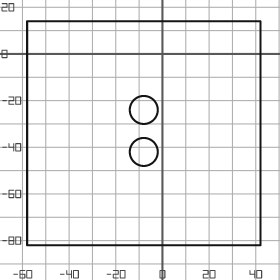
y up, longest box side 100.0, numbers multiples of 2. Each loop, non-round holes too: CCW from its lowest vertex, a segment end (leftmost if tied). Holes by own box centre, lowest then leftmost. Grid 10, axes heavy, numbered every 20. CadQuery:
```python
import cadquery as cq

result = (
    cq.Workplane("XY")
    .moveTo(-58.0, -82.0)
    .lineTo(42.0, -82.0)
    .lineTo(42.0, 14.0)
    .lineTo(-58.0, 14.0)
    .close()
    .moveTo(-8.0, -42.0)
    .circle(6.0)
    .moveTo(-8.0, -24.0)
    .circle(6.0)
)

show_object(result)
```